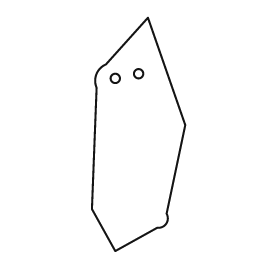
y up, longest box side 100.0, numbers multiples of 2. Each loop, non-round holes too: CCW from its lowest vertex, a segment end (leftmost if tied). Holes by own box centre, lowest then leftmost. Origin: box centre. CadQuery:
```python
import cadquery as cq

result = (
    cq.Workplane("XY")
    .moveTo(-10.0, -50.0)
    .lineTo(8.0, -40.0)
    .threePointArc((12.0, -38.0), (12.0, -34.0))
    .lineTo(20.0, 4.0)
    .lineTo(4.0, 50.0)
    .lineTo(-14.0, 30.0)
    .threePointArc((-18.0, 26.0), (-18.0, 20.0))
    .lineTo(-20.0, -32.0)
    .close()
    .moveTo(-10.0, 24.0)
    .circle(2.0)
    .moveTo(0.0, 26.0)
    .circle(2.0)
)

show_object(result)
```